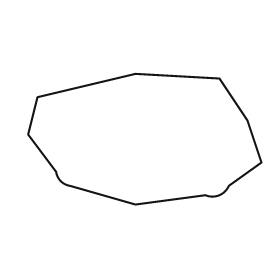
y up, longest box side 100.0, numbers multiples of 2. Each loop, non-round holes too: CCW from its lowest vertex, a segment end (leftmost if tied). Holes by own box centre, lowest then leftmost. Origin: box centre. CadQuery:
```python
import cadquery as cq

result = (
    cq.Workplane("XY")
    .moveTo(-4.0, -28.0)
    .lineTo(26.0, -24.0)
    .threePointArc((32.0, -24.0), (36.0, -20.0))
    .lineTo(50.0, -10.0)
    .lineTo(44.0, 8.0)
    .lineTo(32.0, 26.0)
    .lineTo(-4.0, 28.0)
    .lineTo(-46.0, 18.0)
    .lineTo(-50.0, 2.0)
    .lineTo(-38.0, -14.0)
    .threePointArc((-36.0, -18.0), (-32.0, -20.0))
    .close()
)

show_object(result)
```